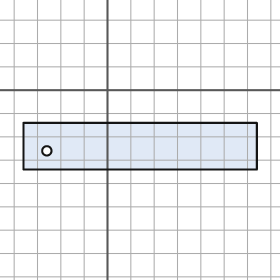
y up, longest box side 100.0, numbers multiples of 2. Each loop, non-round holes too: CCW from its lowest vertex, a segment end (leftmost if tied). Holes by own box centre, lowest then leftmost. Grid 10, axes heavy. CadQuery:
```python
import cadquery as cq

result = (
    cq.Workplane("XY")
    .moveTo(-36.0, -34.0)
    .lineTo(64.0, -34.0)
    .lineTo(64.0, -14.0)
    .lineTo(-36.0, -14.0)
    .close()
    .moveTo(-26.0, -26.0)
    .circle(2.0)
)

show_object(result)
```